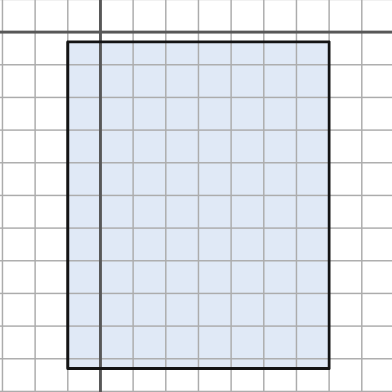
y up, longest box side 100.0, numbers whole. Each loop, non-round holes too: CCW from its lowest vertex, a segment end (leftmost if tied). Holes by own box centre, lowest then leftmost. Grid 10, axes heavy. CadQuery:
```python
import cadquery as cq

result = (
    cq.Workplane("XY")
    .moveTo(-10.0, -103.0)
    .lineTo(70.0, -103.0)
    .lineTo(70.0, -3.0)
    .lineTo(-10.0, -3.0)
    .close()
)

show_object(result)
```